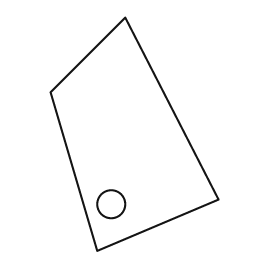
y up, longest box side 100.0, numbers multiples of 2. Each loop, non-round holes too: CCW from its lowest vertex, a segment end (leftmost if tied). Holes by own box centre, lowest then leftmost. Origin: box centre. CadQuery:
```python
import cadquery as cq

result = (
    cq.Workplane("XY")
    .moveTo(-16.0, -50.0)
    .lineTo(36.0, -28.0)
    .lineTo(-4.0, 50.0)
    .lineTo(-36.0, 18.0)
    .close()
    .moveTo(-10.0, -30.0)
    .circle(6.0)
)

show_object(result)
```